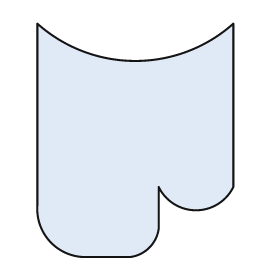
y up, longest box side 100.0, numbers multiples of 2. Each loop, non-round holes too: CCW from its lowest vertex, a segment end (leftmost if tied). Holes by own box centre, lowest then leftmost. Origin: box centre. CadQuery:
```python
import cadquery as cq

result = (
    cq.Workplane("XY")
    .moveTo(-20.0, -50.0)
    .lineTo(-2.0, -50.0)
    .threePointArc((6.0, -46.0), (10.0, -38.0))
    .lineTo(10.0, -20.0)
    .threePointArc((26.0, -30.0), (42.0, -20.0))
    .lineTo(42.0, 50.0)
    .threePointArc((0.0, 34.0), (-42.0, 50.0))
    .lineTo(-42.0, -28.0)
    .threePointArc((-36.0, -44.0), (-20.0, -50.0))
    .close()
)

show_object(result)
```